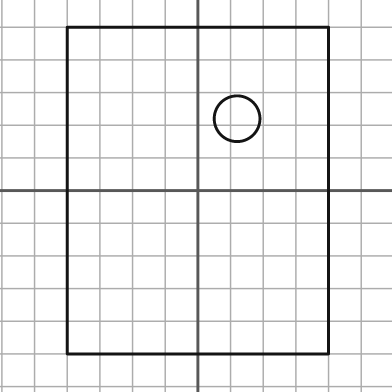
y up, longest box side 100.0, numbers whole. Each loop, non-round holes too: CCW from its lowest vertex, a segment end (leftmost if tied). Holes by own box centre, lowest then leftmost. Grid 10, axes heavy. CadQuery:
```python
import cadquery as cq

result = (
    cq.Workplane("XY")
    .moveTo(-40.0, -50.0)
    .lineTo(40.0, -50.0)
    .lineTo(40.0, 50.0)
    .lineTo(-40.0, 50.0)
    .close()
    .moveTo(12.0, 22.0)
    .circle(7.0)
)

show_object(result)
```